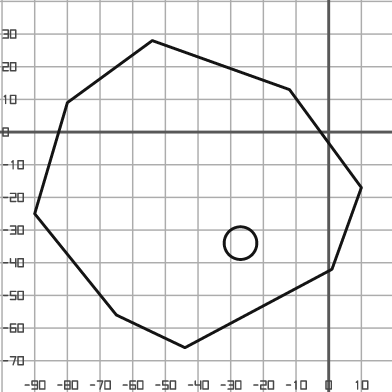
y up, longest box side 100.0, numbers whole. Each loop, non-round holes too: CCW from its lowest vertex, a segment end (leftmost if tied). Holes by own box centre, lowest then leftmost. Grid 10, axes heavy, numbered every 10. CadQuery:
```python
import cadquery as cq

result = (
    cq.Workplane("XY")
    .moveTo(-44.0, -66.0)
    .lineTo(1.0, -42.0)
    .lineTo(10.0, -17.0)
    .lineTo(-12.0, 13.0)
    .lineTo(-54.0, 28.0)
    .lineTo(-80.0, 9.0)
    .lineTo(-90.0, -25.0)
    .lineTo(-65.0, -56.0)
    .close()
    .moveTo(-27.0, -34.0)
    .circle(5.0)
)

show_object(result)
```